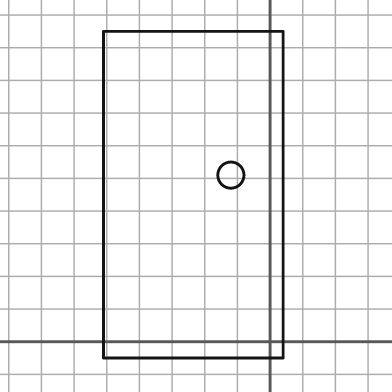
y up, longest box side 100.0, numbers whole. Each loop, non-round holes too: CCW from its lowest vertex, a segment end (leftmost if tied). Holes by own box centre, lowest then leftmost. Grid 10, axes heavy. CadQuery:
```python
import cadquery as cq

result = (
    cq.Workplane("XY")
    .moveTo(-51.0, -5.0)
    .lineTo(4.0, -5.0)
    .lineTo(4.0, 95.0)
    .lineTo(-51.0, 95.0)
    .close()
    .moveTo(-12.0, 51.0)
    .circle(4.0)
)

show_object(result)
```